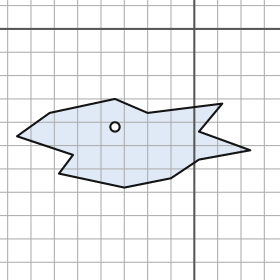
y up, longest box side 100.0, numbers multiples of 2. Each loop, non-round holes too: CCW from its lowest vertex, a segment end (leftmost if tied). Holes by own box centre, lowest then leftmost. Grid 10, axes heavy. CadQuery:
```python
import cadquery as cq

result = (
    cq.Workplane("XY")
    .moveTo(-30.0, -68.0)
    .lineTo(-10.0, -64.0)
    .lineTo(2.0, -56.0)
    .lineTo(24.0, -52.0)
    .lineTo(2.0, -44.0)
    .lineTo(12.0, -32.0)
    .lineTo(-20.0, -36.0)
    .lineTo(-34.0, -30.0)
    .lineTo(-62.0, -36.0)
    .lineTo(-76.0, -46.0)
    .lineTo(-52.0, -54.0)
    .lineTo(-58.0, -62.0)
    .close()
    .moveTo(-34.0, -42.0)
    .circle(2.0)
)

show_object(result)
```